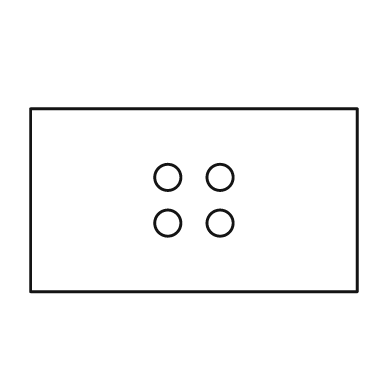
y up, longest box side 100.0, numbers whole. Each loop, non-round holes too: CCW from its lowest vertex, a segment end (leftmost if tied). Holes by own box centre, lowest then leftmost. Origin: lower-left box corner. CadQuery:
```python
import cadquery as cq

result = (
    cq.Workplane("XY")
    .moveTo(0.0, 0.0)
    .lineTo(100.0, 0.0)
    .lineTo(100.0, 56.0)
    .lineTo(0.0, 56.0)
    .close()
    .moveTo(42.0, 21.0)
    .circle(4.0)
    .moveTo(58.0, 21.0)
    .circle(4.0)
    .moveTo(42.0, 35.0)
    .circle(4.0)
    .moveTo(58.0, 35.0)
    .circle(4.0)
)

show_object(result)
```